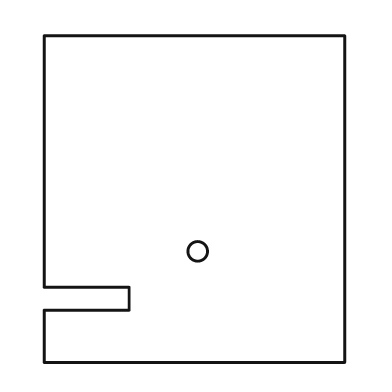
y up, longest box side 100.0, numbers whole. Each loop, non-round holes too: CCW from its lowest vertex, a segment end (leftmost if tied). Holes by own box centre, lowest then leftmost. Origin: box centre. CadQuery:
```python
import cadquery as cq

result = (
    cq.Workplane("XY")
    .moveTo(-46.0, -50.0)
    .lineTo(46.0, -50.0)
    .lineTo(46.0, 50.0)
    .lineTo(-46.0, 50.0)
    .lineTo(-46.0, -27.0)
    .lineTo(-20.0, -27.0)
    .lineTo(-20.0, -34.0)
    .lineTo(-46.0, -34.0)
    .close()
    .moveTo(1.0, -16.0)
    .circle(3.0)
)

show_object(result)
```